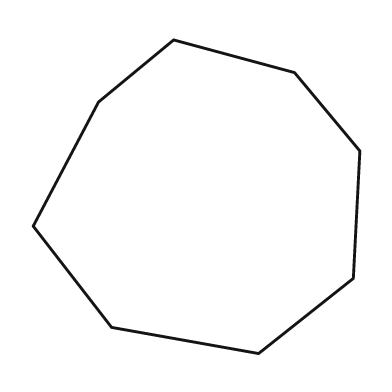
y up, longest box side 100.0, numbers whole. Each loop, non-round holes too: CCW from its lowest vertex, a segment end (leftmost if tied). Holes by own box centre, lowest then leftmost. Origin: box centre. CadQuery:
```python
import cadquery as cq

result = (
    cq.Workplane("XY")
    .moveTo(19.0, -48.0)
    .lineTo(48.0, -25.0)
    .lineTo(50.0, 14.0)
    .lineTo(30.0, 38.0)
    .lineTo(-7.0, 48.0)
    .lineTo(-30.0, 29.0)
    .lineTo(-50.0, -9.0)
    .lineTo(-26.0, -40.0)
    .close()
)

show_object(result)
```